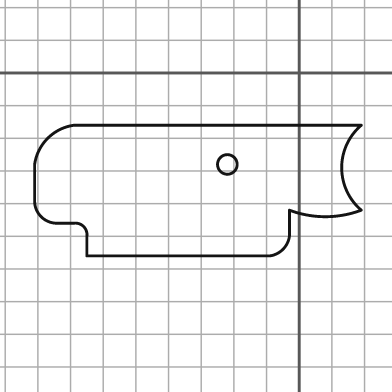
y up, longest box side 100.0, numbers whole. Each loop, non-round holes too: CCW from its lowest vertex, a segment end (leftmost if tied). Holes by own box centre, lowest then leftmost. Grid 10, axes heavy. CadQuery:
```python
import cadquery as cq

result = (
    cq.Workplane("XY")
    .moveTo(-65.0, -56.0)
    .lineTo(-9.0, -56.0)
    .threePointArc((-5.0, -54.0), (-3.0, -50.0))
    .lineTo(-3.0, -42.0)
    .threePointArc((8.0, -44.0), (19.0, -42.0))
    .threePointArc((13.0, -29.0), (19.0, -16.0))
    .lineTo(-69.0, -16.0)
    .threePointArc((-77.0, -20.0), (-81.0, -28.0))
    .lineTo(-81.0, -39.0)
    .threePointArc((-79.0, -44.0), (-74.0, -46.0))
    .lineTo(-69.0, -46.0)
    .threePointArc((-66.0, -47.0), (-65.0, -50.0))
    .close()
    .moveTo(-22.0, -28.0)
    .circle(3.0)
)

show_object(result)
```